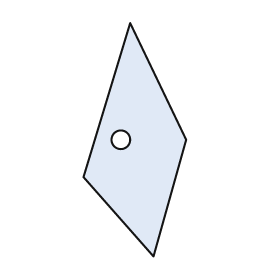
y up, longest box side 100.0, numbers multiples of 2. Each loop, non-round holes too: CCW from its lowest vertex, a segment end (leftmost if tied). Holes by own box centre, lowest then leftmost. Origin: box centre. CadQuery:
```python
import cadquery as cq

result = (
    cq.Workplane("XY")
    .moveTo(8.0, -50.0)
    .lineTo(22.0, 0.0)
    .lineTo(-2.0, 50.0)
    .lineTo(-22.0, -16.0)
    .close()
    .moveTo(-6.0, 0.0)
    .circle(4.0)
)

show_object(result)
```